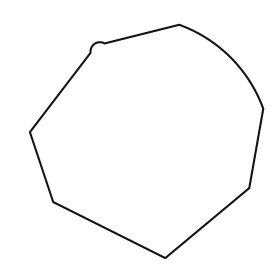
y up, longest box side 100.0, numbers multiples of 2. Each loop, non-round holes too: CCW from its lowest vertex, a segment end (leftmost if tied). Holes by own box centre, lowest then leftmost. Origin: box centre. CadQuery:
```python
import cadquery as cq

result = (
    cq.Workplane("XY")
    .moveTo(8.0, -50.0)
    .lineTo(44.0, -20.0)
    .lineTo(50.0, 14.0)
    .threePointArc((36.0, 36.0), (14.0, 50.0))
    .lineTo(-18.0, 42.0)
    .threePointArc((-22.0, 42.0), (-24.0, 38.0))
    .lineTo(-50.0, 4.0)
    .lineTo(-40.0, -26.0)
    .close()
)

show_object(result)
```